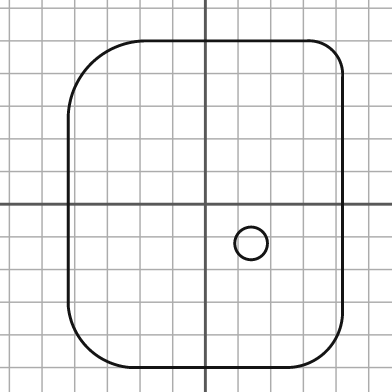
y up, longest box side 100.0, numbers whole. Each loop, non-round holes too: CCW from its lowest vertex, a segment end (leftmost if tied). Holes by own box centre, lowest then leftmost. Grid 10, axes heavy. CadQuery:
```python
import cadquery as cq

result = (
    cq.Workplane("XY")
    .moveTo(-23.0, -50.0)
    .lineTo(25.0, -50.0)
    .threePointArc((37.0, -45.0), (42.0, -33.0))
    .lineTo(42.0, 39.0)
    .threePointArc((39.0, 47.0), (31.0, 50.0))
    .lineTo(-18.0, 50.0)
    .threePointArc((-35.0, 43.0), (-42.0, 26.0))
    .lineTo(-42.0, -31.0)
    .threePointArc((-36.0, -44.0), (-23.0, -50.0))
    .close()
    .moveTo(14.0, -12.0)
    .circle(5.0)
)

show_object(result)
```